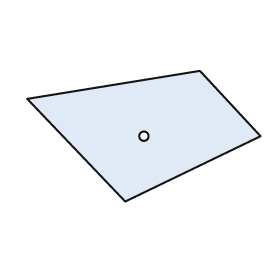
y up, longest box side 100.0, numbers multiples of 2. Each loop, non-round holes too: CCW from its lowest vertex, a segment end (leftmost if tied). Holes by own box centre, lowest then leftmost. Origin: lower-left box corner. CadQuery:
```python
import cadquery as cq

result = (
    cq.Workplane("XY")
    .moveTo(42.0, 0.0)
    .lineTo(100.0, 28.0)
    .lineTo(74.0, 56.0)
    .lineTo(0.0, 44.0)
    .close()
    .moveTo(50.0, 28.0)
    .circle(2.0)
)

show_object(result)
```